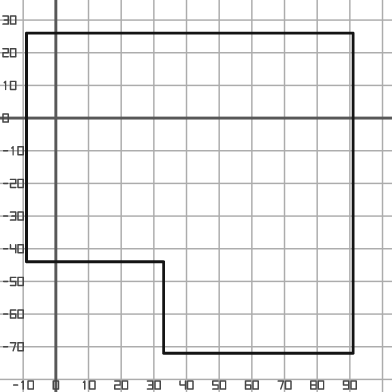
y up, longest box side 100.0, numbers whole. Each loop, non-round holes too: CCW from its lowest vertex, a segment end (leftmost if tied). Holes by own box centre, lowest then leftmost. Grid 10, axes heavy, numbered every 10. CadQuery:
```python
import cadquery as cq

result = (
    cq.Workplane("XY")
    .moveTo(33.0, -72.0)
    .lineTo(91.0, -72.0)
    .lineTo(91.0, 26.0)
    .lineTo(-9.0, 26.0)
    .lineTo(-9.0, -44.0)
    .lineTo(33.0, -44.0)
    .close()
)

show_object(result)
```